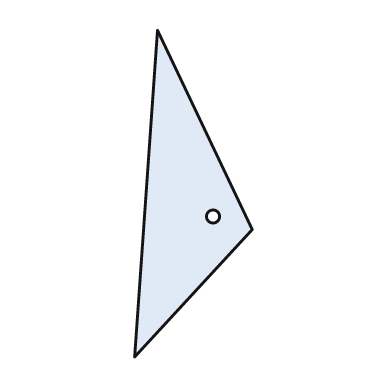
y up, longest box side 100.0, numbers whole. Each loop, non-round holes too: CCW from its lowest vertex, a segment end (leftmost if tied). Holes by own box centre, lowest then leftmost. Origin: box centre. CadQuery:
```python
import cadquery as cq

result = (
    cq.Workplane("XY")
    .moveTo(-18.0, -50.0)
    .lineTo(18.0, -11.0)
    .lineTo(-11.0, 50.0)
    .close()
    .moveTo(6.0, -7.0)
    .circle(2.0)
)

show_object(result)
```